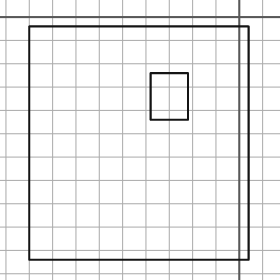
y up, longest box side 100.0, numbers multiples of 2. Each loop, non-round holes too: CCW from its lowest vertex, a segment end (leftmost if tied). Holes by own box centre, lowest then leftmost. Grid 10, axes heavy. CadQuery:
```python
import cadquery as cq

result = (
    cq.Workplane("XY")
    .moveTo(-90.0, -104.0)
    .lineTo(4.0, -104.0)
    .lineTo(4.0, -4.0)
    .lineTo(-90.0, -4.0)
    .close()
    .moveTo(-38.0, -44.0)
    .lineTo(-22.0, -44.0)
    .lineTo(-22.0, -24.0)
    .lineTo(-38.0, -24.0)
    .close()
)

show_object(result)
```